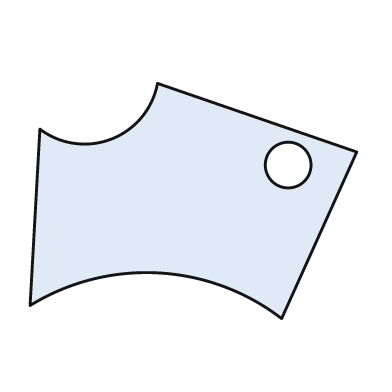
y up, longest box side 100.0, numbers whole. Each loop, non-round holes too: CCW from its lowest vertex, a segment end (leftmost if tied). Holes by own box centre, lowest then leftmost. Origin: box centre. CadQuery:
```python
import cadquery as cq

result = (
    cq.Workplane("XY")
    .moveTo(27.0, -36.0)
    .lineTo(50.0, 15.0)
    .lineTo(-11.0, 36.0)
    .threePointArc((-25.0, 19.0), (-47.0, 22.0))
    .lineTo(-50.0, -32.0)
    .threePointArc((-11.0, -22.0), (27.0, -36.0))
    .close()
    .moveTo(29.0, 11.0)
    .circle(7.0)
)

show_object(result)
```